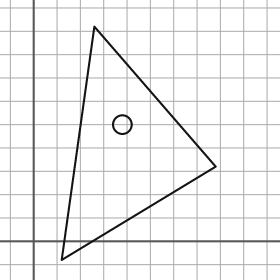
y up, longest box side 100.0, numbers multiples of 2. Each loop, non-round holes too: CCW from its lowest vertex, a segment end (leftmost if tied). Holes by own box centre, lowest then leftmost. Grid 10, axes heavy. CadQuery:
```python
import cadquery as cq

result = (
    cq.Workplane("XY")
    .moveTo(12.0, -8.0)
    .lineTo(78.0, 32.0)
    .lineTo(26.0, 92.0)
    .close()
    .moveTo(38.0, 50.0)
    .circle(4.0)
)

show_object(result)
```